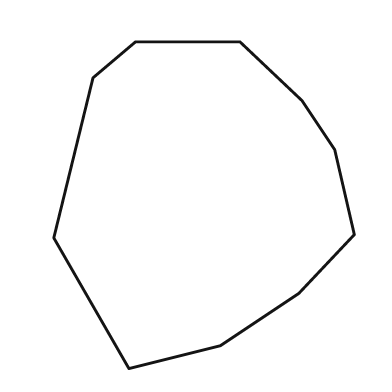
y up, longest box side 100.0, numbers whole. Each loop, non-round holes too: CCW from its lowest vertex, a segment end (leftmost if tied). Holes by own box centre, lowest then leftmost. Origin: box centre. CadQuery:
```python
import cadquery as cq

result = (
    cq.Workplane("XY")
    .moveTo(-23.0, -50.0)
    .lineTo(5.0, -43.0)
    .lineTo(29.0, -27.0)
    .lineTo(46.0, -9.0)
    .lineTo(40.0, 17.0)
    .lineTo(30.0, 32.0)
    .lineTo(11.0, 50.0)
    .lineTo(-21.0, 50.0)
    .lineTo(-34.0, 39.0)
    .lineTo(-46.0, -10.0)
    .close()
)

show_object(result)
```